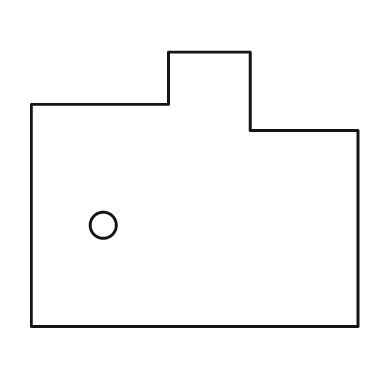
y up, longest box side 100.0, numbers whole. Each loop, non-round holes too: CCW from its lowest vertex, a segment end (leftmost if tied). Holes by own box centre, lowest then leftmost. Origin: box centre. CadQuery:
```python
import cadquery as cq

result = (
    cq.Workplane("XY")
    .moveTo(-50.0, -42.0)
    .lineTo(50.0, -42.0)
    .lineTo(50.0, 18.0)
    .lineTo(17.0, 18.0)
    .lineTo(17.0, 42.0)
    .lineTo(-8.0, 42.0)
    .lineTo(-8.0, 26.0)
    .lineTo(-50.0, 26.0)
    .close()
    .moveTo(-28.0, -11.0)
    .circle(4.0)
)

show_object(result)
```